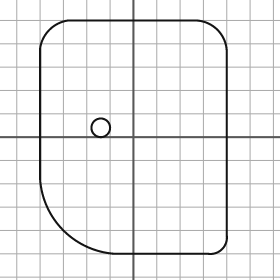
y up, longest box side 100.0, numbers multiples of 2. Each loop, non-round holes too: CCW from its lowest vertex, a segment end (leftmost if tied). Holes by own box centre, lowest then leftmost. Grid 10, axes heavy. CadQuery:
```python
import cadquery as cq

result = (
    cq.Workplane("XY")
    .moveTo(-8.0, -50.0)
    .lineTo(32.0, -50.0)
    .threePointArc((38.0, -48.0), (40.0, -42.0))
    .lineTo(40.0, 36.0)
    .threePointArc((36.0, 46.0), (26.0, 50.0))
    .lineTo(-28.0, 50.0)
    .threePointArc((-36.0, 46.0), (-40.0, 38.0))
    .lineTo(-40.0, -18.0)
    .threePointArc((-30.0, -40.0), (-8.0, -50.0))
    .close()
    .moveTo(-14.0, 4.0)
    .circle(4.0)
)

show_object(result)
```